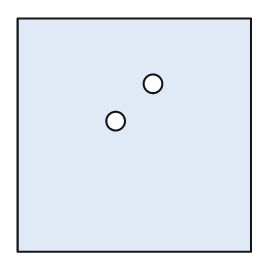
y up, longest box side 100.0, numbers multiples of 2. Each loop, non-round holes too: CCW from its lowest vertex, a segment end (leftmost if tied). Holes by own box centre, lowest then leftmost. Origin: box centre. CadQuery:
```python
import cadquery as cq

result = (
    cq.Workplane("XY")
    .moveTo(-50.0, -50.0)
    .lineTo(50.0, -50.0)
    .lineTo(50.0, 50.0)
    .lineTo(-50.0, 50.0)
    .close()
    .moveTo(-8.0, 6.0)
    .circle(4.0)
    .moveTo(8.0, 22.0)
    .circle(4.0)
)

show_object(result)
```